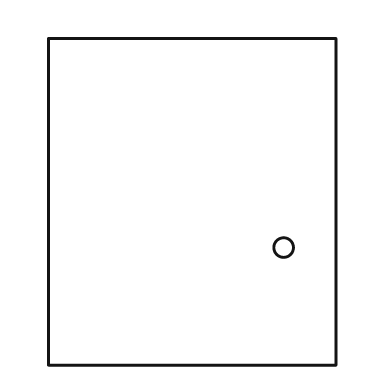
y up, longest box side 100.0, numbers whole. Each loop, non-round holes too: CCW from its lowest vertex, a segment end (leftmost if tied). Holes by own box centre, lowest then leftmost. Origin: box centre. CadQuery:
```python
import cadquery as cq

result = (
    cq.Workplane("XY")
    .moveTo(-44.0, -50.0)
    .lineTo(44.0, -50.0)
    .lineTo(44.0, 50.0)
    .lineTo(-44.0, 50.0)
    .close()
    .moveTo(28.0, -14.0)
    .circle(3.0)
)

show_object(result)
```